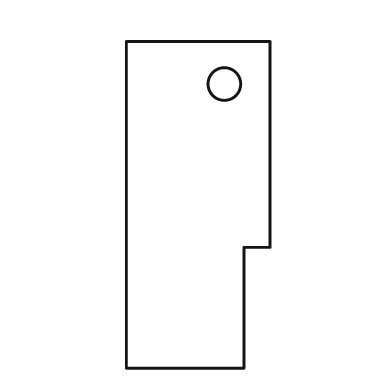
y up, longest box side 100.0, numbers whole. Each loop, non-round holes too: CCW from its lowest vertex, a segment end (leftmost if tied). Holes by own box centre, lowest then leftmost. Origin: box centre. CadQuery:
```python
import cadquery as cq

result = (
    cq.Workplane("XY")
    .moveTo(-22.0, -50.0)
    .lineTo(14.0, -50.0)
    .lineTo(14.0, -13.0)
    .lineTo(22.0, -13.0)
    .lineTo(22.0, 50.0)
    .lineTo(-22.0, 50.0)
    .close()
    .moveTo(8.0, 37.0)
    .circle(5.0)
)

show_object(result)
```